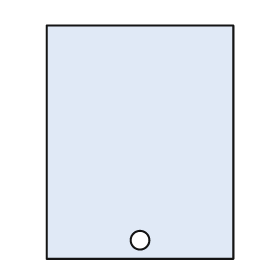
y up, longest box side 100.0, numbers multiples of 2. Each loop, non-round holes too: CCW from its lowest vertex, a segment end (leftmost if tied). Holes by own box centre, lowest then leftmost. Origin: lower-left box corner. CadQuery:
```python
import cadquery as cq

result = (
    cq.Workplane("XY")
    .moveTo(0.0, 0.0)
    .lineTo(80.0, 0.0)
    .lineTo(80.0, 100.0)
    .lineTo(0.0, 100.0)
    .close()
    .moveTo(40.0, 8.0)
    .circle(4.0)
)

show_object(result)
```